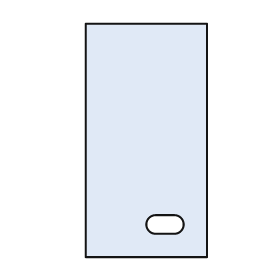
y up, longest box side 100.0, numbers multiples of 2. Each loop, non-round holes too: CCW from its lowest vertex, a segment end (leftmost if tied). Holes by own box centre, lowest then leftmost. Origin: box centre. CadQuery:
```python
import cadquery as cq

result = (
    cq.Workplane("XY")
    .moveTo(-26.0, -50.0)
    .lineTo(26.0, -50.0)
    .lineTo(26.0, 50.0)
    .lineTo(-26.0, 50.0)
    .close()
    .moveTo(4.0, -40.0)
    .lineTo(12.0, -40.0)
    .threePointArc((16.0, -36.0), (12.0, -32.0))
    .lineTo(4.0, -32.0)
    .threePointArc((0.0, -36.0), (4.0, -40.0))
    .close()
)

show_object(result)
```